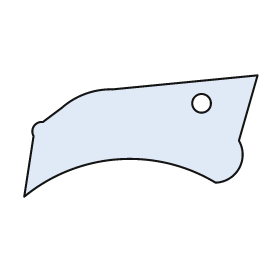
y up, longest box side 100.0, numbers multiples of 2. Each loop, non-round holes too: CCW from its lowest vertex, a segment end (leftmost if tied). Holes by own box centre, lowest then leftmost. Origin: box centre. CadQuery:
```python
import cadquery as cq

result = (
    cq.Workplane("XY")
    .moveTo(-50.0, -26.0)
    .threePointArc((-10.0, -10.0), (32.0, -20.0))
    .threePointArc((42.0, -14.0), (42.0, -2.0))
    .lineTo(50.0, 26.0)
    .lineTo(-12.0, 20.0)
    .threePointArc((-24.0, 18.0), (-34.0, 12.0))
    .lineTo(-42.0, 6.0)
    .threePointArc((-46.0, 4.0), (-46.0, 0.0))
    .close()
    .moveTo(26.0, 14.0)
    .circle(4.0)
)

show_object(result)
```